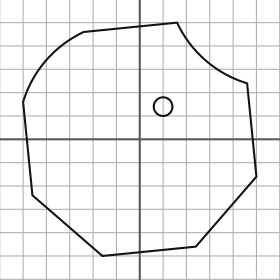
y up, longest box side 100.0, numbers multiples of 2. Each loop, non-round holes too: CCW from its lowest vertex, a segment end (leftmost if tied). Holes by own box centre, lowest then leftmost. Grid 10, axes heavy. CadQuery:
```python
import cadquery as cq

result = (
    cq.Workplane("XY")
    .moveTo(-16.0, -50.0)
    .lineTo(24.0, -46.0)
    .lineTo(50.0, -16.0)
    .lineTo(46.0, 24.0)
    .threePointArc((28.0, 34.0), (16.0, 50.0))
    .lineTo(-24.0, 46.0)
    .threePointArc((-40.0, 34.0), (-50.0, 16.0))
    .lineTo(-46.0, -24.0)
    .close()
    .moveTo(10.0, 14.0)
    .circle(4.0)
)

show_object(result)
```